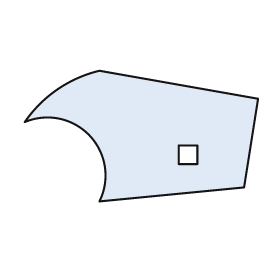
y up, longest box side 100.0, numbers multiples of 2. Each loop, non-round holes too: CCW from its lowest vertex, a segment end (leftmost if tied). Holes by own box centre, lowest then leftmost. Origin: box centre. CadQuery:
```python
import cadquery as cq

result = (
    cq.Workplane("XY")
    .moveTo(-18.0, -28.0)
    .lineTo(44.0, -22.0)
    .lineTo(50.0, 16.0)
    .lineTo(-18.0, 28.0)
    .threePointArc((-36.0, 20.0), (-50.0, 6.0))
    .threePointArc((-22.0, 0.0), (-18.0, -28.0))
    .close()
    .moveTo(16.0, -12.0)
    .lineTo(24.0, -12.0)
    .lineTo(24.0, -4.0)
    .lineTo(16.0, -4.0)
    .close()
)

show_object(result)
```